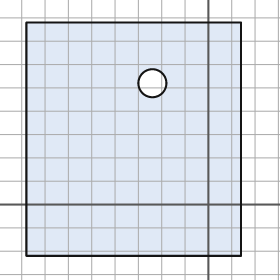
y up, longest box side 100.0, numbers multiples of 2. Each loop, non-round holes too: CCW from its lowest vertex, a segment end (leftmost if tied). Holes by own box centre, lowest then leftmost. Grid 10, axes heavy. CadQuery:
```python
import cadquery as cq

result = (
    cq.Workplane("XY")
    .moveTo(-78.0, -22.0)
    .lineTo(14.0, -22.0)
    .lineTo(14.0, 78.0)
    .lineTo(-78.0, 78.0)
    .close()
    .moveTo(-24.0, 52.0)
    .circle(6.0)
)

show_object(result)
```